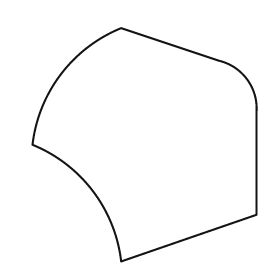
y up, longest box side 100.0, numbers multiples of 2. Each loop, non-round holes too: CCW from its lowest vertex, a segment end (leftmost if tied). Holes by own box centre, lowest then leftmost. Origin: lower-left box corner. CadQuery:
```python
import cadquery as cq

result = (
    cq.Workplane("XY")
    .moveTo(38.0, 0.0)
    .lineTo(96.0, 20.0)
    .lineTo(96.0, 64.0)
    .threePointArc((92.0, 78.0), (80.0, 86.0))
    .lineTo(38.0, 100.0)
    .threePointArc((12.0, 80.0), (0.0, 50.0))
    .threePointArc((26.0, 30.0), (38.0, 0.0))
    .close()
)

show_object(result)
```